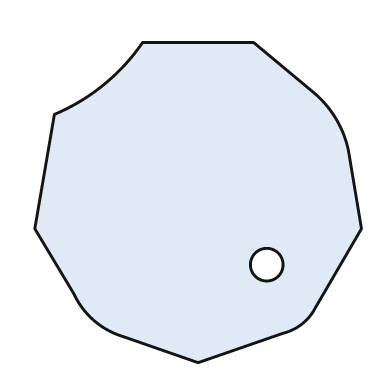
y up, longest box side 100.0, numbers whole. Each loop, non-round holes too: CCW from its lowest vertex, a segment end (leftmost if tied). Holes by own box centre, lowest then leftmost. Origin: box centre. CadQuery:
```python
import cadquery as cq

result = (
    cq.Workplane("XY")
    .moveTo(0.0, -49.0)
    .lineTo(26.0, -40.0)
    .threePointArc((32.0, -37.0), (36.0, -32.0))
    .lineTo(50.0, -8.0)
    .lineTo(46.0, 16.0)
    .threePointArc((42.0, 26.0), (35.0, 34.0))
    .lineTo(17.0, 49.0)
    .lineTo(-17.0, 49.0)
    .threePointArc((-29.0, 36.0), (-44.0, 27.0))
    .lineTo(-50.0, -8.0)
    .lineTo(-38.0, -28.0)
    .threePointArc((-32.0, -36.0), (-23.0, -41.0))
    .close()
    .moveTo(21.0, -19.0)
    .circle(5.0)
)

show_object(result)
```